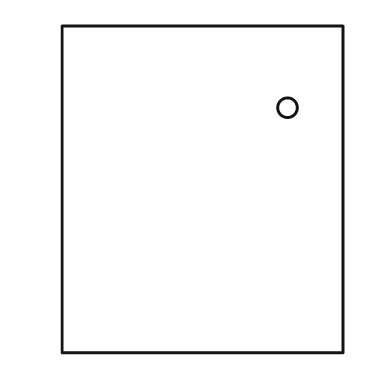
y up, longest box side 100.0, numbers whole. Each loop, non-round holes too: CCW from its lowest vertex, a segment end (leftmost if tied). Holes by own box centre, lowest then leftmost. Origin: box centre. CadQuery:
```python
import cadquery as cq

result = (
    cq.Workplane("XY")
    .moveTo(-43.0, -50.0)
    .lineTo(43.0, -50.0)
    .lineTo(43.0, 50.0)
    .lineTo(-43.0, 50.0)
    .close()
    .moveTo(26.0, 25.0)
    .circle(3.0)
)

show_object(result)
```